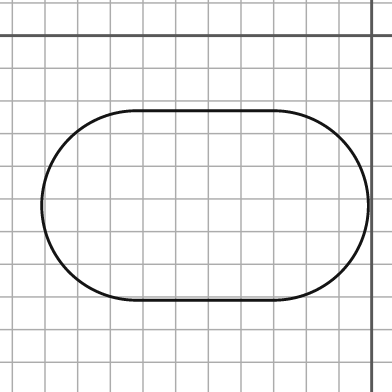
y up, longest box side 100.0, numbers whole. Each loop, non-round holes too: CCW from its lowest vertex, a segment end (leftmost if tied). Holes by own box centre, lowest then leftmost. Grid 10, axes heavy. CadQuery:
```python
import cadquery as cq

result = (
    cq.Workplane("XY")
    .moveTo(-72.0, -81.0)
    .lineTo(-30.0, -81.0)
    .threePointArc((-1.0, -52.0), (-30.0, -23.0))
    .lineTo(-72.0, -23.0)
    .threePointArc((-101.0, -52.0), (-72.0, -81.0))
    .close()
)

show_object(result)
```